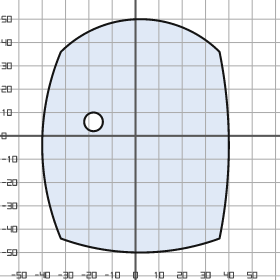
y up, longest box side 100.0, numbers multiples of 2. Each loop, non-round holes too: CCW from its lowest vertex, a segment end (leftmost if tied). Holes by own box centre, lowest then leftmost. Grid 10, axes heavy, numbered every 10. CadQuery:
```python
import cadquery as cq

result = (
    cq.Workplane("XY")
    .moveTo(-32.0, -44.0)
    .threePointArc((2.0, -50.0), (36.0, -44.0))
    .threePointArc((40.0, -4.0), (36.0, 36.0))
    .threePointArc((2.0, 50.0), (-32.0, 36.0))
    .threePointArc((-40.0, -4.0), (-32.0, -44.0))
    .close()
    .moveTo(-18.0, 6.0)
    .circle(4.0)
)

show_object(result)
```